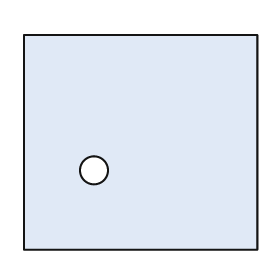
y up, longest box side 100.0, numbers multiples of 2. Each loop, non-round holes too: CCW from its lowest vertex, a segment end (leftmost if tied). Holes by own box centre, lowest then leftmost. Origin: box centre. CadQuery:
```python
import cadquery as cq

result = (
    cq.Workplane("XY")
    .moveTo(-50.0, -46.0)
    .lineTo(50.0, -46.0)
    .lineTo(50.0, 46.0)
    .lineTo(-50.0, 46.0)
    .close()
    .moveTo(-20.0, -12.0)
    .circle(6.0)
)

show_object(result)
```